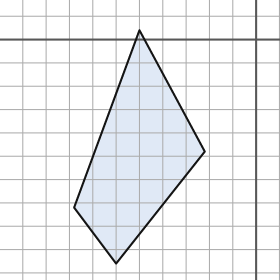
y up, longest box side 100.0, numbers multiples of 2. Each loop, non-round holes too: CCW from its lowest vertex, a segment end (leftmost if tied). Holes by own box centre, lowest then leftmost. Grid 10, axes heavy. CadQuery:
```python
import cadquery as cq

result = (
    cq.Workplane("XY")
    .moveTo(-60.0, -96.0)
    .lineTo(-22.0, -48.0)
    .lineTo(-50.0, 4.0)
    .lineTo(-78.0, -72.0)
    .close()
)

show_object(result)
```